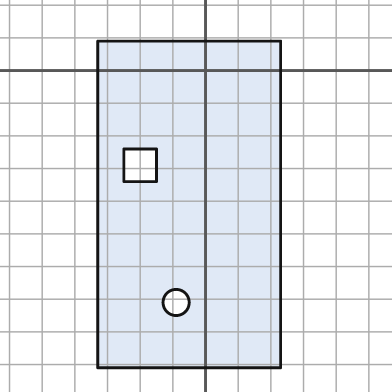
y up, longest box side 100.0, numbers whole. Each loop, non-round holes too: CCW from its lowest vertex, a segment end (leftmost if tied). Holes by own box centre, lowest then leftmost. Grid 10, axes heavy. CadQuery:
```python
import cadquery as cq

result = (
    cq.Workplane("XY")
    .moveTo(-33.0, -91.0)
    .lineTo(23.0, -91.0)
    .lineTo(23.0, 9.0)
    .lineTo(-33.0, 9.0)
    .close()
    .moveTo(-9.0, -71.0)
    .circle(4.0)
    .moveTo(-25.0, -34.0)
    .lineTo(-15.0, -34.0)
    .lineTo(-15.0, -24.0)
    .lineTo(-25.0, -24.0)
    .close()
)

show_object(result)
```